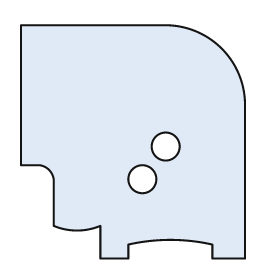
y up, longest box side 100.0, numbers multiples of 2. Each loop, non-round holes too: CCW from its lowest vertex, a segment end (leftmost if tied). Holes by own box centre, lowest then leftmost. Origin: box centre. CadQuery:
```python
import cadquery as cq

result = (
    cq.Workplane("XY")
    .moveTo(-14.0, -50.0)
    .lineTo(-2.0, -50.0)
    .lineTo(-2.0, -44.0)
    .threePointArc((16.0, -42.0), (34.0, -44.0))
    .lineTo(34.0, -50.0)
    .lineTo(48.0, -50.0)
    .lineTo(48.0, 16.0)
    .threePointArc((38.0, 40.0), (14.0, 50.0))
    .lineTo(-48.0, 50.0)
    .lineTo(-48.0, -10.0)
    .lineTo(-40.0, -10.0)
    .threePointArc((-36.0, -12.0), (-34.0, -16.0))
    .lineTo(-34.0, -36.0)
    .threePointArc((-24.0, -38.0), (-14.0, -36.0))
    .close()
    .moveTo(4.0, -16.0)
    .circle(6.0)
    .moveTo(14.0, -2.0)
    .circle(6.0)
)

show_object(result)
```